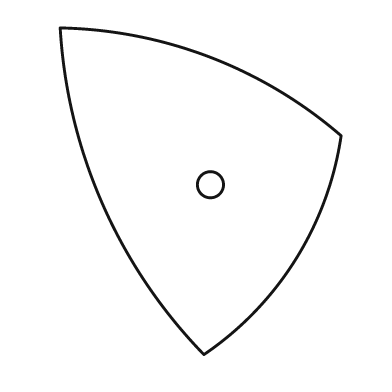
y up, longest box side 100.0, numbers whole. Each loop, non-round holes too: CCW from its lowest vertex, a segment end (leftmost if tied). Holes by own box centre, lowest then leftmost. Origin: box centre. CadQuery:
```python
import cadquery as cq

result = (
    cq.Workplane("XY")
    .moveTo(1.0, -50.0)
    .threePointArc((29.0, -21.0), (43.0, 17.0))
    .threePointArc((3.0, 41.0), (-43.0, 50.0))
    .threePointArc((-30.0, -4.0), (1.0, -50.0))
    .close()
    .moveTo(3.0, 2.0)
    .circle(4.0)
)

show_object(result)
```